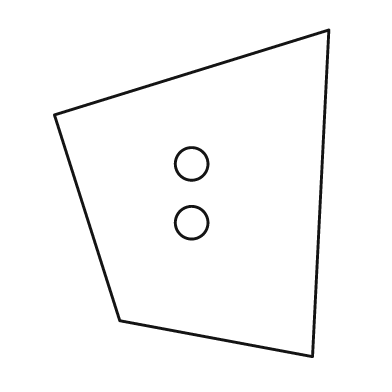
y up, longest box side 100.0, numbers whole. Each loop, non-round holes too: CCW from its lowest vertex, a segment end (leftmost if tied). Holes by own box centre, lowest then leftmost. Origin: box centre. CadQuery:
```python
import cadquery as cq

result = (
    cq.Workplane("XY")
    .moveTo(37.0, -50.0)
    .lineTo(42.0, 50.0)
    .lineTo(-42.0, 24.0)
    .lineTo(-22.0, -39.0)
    .close()
    .moveTo(0.0, -9.0)
    .circle(5.0)
    .moveTo(0.0, 9.0)
    .circle(5.0)
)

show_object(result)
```